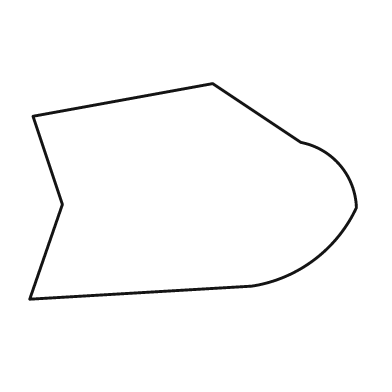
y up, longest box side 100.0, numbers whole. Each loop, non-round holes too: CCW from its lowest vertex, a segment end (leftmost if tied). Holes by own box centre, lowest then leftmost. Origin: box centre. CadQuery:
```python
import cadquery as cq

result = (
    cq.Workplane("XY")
    .moveTo(-50.0, -33.0)
    .lineTo(18.0, -29.0)
    .threePointArc((37.0, -21.0), (50.0, -5.0))
    .threePointArc((45.0, 8.0), (33.0, 15.0))
    .lineTo(6.0, 33.0)
    .lineTo(-49.0, 23.0)
    .lineTo(-40.0, -4.0)
    .close()
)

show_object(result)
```